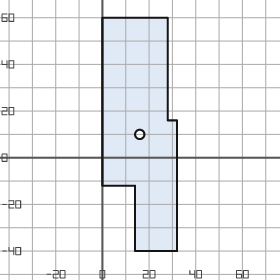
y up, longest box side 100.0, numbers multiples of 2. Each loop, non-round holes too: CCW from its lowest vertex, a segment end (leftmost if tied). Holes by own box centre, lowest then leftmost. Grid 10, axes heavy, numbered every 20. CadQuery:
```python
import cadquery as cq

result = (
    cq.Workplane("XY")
    .moveTo(14.0, -40.0)
    .lineTo(32.0, -40.0)
    .lineTo(32.0, 16.0)
    .lineTo(28.0, 16.0)
    .lineTo(28.0, 60.0)
    .lineTo(0.0, 60.0)
    .lineTo(0.0, -12.0)
    .lineTo(14.0, -12.0)
    .close()
    .moveTo(16.0, 10.0)
    .circle(2.0)
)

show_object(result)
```